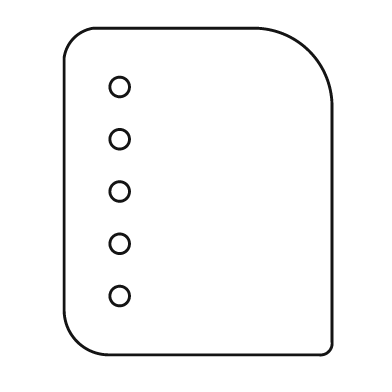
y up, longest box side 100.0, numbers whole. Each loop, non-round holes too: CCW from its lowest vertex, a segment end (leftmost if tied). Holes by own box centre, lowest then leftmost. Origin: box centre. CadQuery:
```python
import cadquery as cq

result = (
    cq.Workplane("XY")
    .moveTo(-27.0, -50.0)
    .lineTo(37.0, -50.0)
    .threePointArc((40.0, -49.0), (41.0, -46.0))
    .lineTo(41.0, 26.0)
    .threePointArc((34.0, 43.0), (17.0, 50.0))
    .lineTo(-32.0, 50.0)
    .threePointArc((-38.0, 47.0), (-41.0, 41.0))
    .lineTo(-41.0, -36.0)
    .threePointArc((-37.0, -46.0), (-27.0, -50.0))
    .close()
    .moveTo(-24.0, -32.0)
    .circle(3.0)
    .moveTo(-24.0, -16.0)
    .circle(3.0)
    .moveTo(-24.0, 0.0)
    .circle(3.0)
    .moveTo(-24.0, 16.0)
    .circle(3.0)
    .moveTo(-24.0, 32.0)
    .circle(3.0)
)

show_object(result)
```